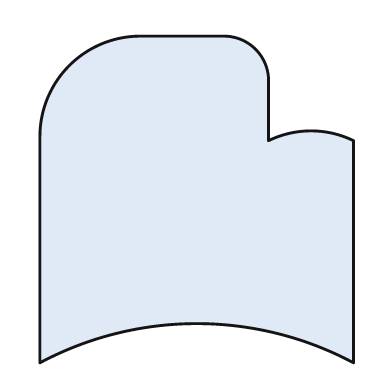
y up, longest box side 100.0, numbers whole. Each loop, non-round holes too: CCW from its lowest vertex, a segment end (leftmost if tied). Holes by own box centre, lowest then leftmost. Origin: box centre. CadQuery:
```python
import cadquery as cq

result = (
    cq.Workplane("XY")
    .moveTo(-48.0, -50.0)
    .threePointArc((0.0, -38.0), (48.0, -50.0))
    .lineTo(48.0, 18.0)
    .threePointArc((35.0, 21.0), (22.0, 18.0))
    .lineTo(22.0, 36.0)
    .threePointArc((18.0, 46.0), (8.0, 50.0))
    .lineTo(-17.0, 50.0)
    .threePointArc((-39.0, 41.0), (-48.0, 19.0))
    .close()
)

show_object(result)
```